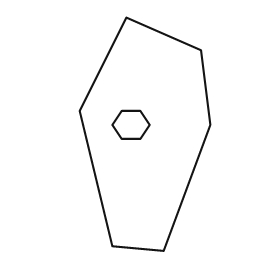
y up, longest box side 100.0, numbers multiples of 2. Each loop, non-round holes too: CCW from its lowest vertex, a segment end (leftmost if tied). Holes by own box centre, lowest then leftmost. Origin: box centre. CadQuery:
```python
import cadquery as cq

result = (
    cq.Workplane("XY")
    .moveTo(8.0, -50.0)
    .lineTo(28.0, 4.0)
    .lineTo(24.0, 36.0)
    .lineTo(-8.0, 50.0)
    .lineTo(-28.0, 10.0)
    .lineTo(-14.0, -48.0)
    .close()
    .moveTo(-10.0, -2.0)
    .lineTo(-2.0, -2.0)
    .lineTo(2.0, 4.0)
    .lineTo(-2.0, 10.0)
    .lineTo(-10.0, 10.0)
    .lineTo(-14.0, 4.0)
    .close()
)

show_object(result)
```